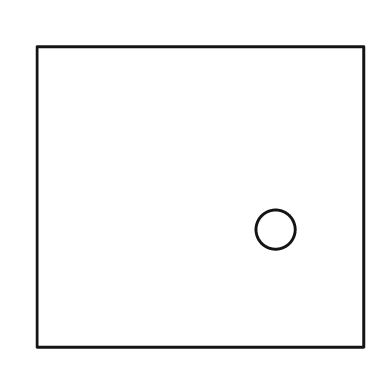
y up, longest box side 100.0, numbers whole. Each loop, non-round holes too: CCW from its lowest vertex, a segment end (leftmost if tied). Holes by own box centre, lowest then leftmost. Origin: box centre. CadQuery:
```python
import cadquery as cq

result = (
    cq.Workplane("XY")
    .moveTo(-50.0, -46.0)
    .lineTo(50.0, -46.0)
    .lineTo(50.0, 46.0)
    .lineTo(-50.0, 46.0)
    .close()
    .moveTo(23.0, -10.0)
    .circle(6.0)
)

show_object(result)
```